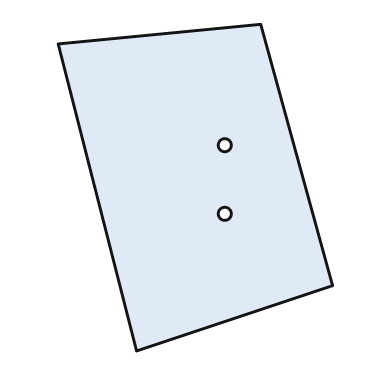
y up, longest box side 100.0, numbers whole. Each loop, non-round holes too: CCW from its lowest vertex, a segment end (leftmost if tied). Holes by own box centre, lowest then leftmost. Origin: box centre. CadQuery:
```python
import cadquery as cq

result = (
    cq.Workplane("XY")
    .moveTo(-18.0, -50.0)
    .lineTo(42.0, -30.0)
    .lineTo(20.0, 50.0)
    .lineTo(-42.0, 44.0)
    .close()
    .moveTo(9.0, -8.0)
    .circle(2.0)
    .moveTo(9.0, 13.0)
    .circle(2.0)
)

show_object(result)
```